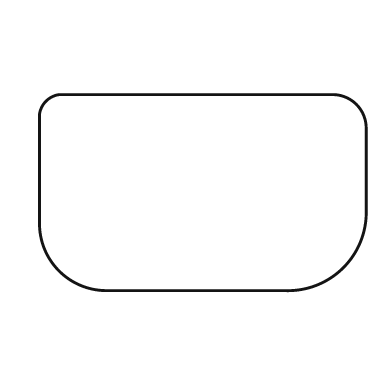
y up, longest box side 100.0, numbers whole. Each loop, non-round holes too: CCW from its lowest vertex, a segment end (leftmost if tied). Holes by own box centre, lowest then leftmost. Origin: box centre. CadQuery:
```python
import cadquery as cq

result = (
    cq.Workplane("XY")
    .moveTo(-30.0, -30.0)
    .lineTo(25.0, -30.0)
    .threePointArc((43.0, -23.0), (50.0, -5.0))
    .lineTo(50.0, 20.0)
    .threePointArc((47.0, 27.0), (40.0, 30.0))
    .lineTo(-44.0, 30.0)
    .threePointArc((-48.0, 28.0), (-50.0, 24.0))
    .lineTo(-50.0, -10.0)
    .threePointArc((-44.0, -24.0), (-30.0, -30.0))
    .close()
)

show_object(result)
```